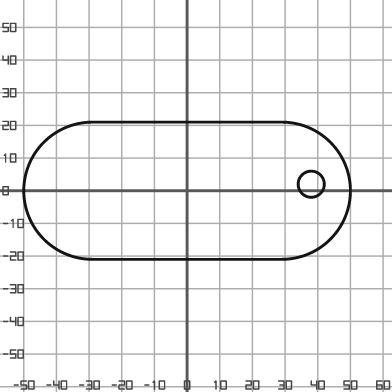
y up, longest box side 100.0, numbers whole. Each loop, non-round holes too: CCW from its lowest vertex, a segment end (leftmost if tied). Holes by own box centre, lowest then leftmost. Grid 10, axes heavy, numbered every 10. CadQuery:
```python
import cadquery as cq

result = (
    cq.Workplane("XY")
    .moveTo(-29.0, -21.0)
    .lineTo(29.0, -21.0)
    .threePointArc((50.0, 0.0), (29.0, 21.0))
    .lineTo(-29.0, 21.0)
    .threePointArc((-50.0, 0.0), (-29.0, -21.0))
    .close()
    .moveTo(38.0, 2.0)
    .circle(4.0)
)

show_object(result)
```